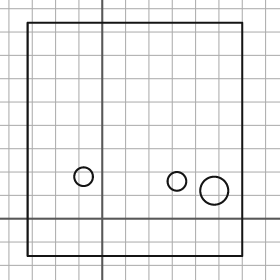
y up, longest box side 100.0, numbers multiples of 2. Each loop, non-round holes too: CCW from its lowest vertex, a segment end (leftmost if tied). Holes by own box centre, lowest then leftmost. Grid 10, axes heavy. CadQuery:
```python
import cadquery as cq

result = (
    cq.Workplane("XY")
    .moveTo(-32.0, -16.0)
    .lineTo(60.0, -16.0)
    .lineTo(60.0, 84.0)
    .lineTo(-32.0, 84.0)
    .close()
    .moveTo(48.0, 12.0)
    .circle(6.0)
    .moveTo(32.0, 16.0)
    .circle(4.0)
    .moveTo(-8.0, 18.0)
    .circle(4.0)
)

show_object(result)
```